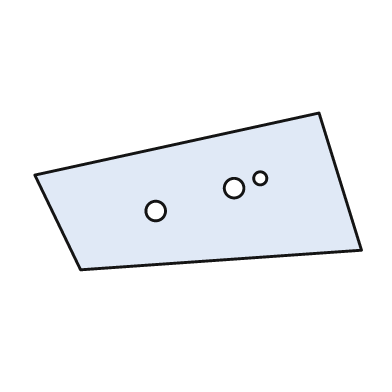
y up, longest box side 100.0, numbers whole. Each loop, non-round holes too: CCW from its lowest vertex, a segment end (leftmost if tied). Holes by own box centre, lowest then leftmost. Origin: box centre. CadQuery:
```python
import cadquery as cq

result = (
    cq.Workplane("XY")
    .moveTo(-36.0, -24.0)
    .lineTo(50.0, -18.0)
    .lineTo(37.0, 24.0)
    .lineTo(-50.0, 5.0)
    .close()
    .moveTo(-13.0, -6.0)
    .circle(3.0)
    .moveTo(11.0, 1.0)
    .circle(3.0)
    .moveTo(19.0, 4.0)
    .circle(2.0)
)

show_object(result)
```